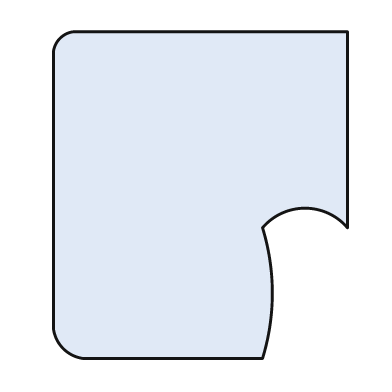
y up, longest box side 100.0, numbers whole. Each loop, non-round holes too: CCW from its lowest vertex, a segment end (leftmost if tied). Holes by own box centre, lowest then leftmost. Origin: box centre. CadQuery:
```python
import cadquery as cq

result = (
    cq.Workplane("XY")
    .moveTo(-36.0, -50.0)
    .lineTo(19.0, -50.0)
    .threePointArc((22.0, -30.0), (19.0, -10.0))
    .threePointArc((32.0, -4.0), (45.0, -10.0))
    .lineTo(45.0, 50.0)
    .lineTo(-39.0, 50.0)
    .threePointArc((-43.0, 48.0), (-45.0, 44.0))
    .lineTo(-45.0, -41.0)
    .threePointArc((-42.0, -47.0), (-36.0, -50.0))
    .close()
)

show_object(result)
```